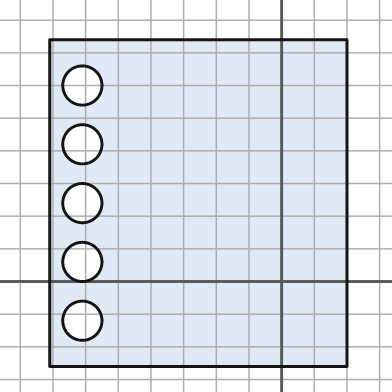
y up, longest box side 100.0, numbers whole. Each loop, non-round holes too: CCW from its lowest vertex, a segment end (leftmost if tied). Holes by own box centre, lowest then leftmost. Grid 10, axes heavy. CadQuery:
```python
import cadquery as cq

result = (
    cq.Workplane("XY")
    .moveTo(-71.0, -26.0)
    .lineTo(20.0, -26.0)
    .lineTo(20.0, 74.0)
    .lineTo(-71.0, 74.0)
    .close()
    .moveTo(-61.0, -12.0)
    .circle(6.0)
    .moveTo(-61.0, 6.0)
    .circle(6.0)
    .moveTo(-61.0, 24.0)
    .circle(6.0)
    .moveTo(-61.0, 42.0)
    .circle(6.0)
    .moveTo(-61.0, 60.0)
    .circle(6.0)
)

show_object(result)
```